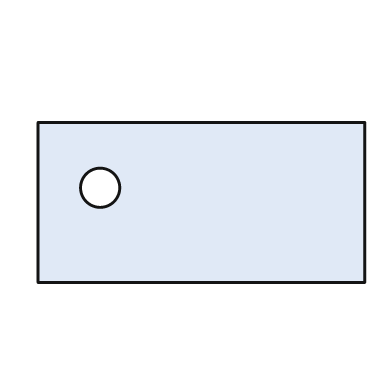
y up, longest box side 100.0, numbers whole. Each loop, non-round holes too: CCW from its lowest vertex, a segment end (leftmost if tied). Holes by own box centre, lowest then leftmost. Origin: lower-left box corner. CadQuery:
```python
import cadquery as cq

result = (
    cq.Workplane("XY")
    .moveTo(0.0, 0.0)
    .lineTo(100.0, 0.0)
    .lineTo(100.0, 49.0)
    .lineTo(0.0, 49.0)
    .close()
    .moveTo(19.0, 29.0)
    .circle(6.0)
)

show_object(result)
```